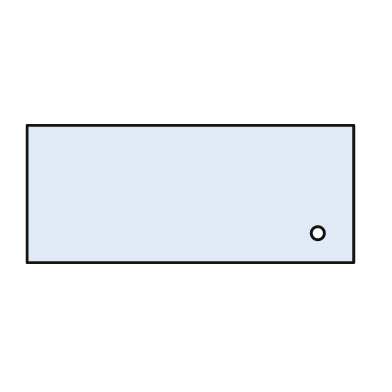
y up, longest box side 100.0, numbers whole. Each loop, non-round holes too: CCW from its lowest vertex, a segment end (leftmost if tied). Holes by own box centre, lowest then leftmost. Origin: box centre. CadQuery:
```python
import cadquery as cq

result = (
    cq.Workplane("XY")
    .moveTo(-50.0, -21.0)
    .lineTo(50.0, -21.0)
    .lineTo(50.0, 21.0)
    .lineTo(-50.0, 21.0)
    .close()
    .moveTo(39.0, -12.0)
    .circle(2.0)
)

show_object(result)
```